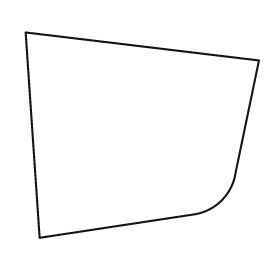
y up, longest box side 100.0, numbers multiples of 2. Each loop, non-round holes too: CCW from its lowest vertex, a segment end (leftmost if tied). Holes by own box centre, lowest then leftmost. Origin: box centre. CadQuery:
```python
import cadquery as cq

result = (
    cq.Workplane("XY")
    .moveTo(-44.0, -44.0)
    .lineTo(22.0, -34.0)
    .threePointArc((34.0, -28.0), (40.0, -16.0))
    .lineTo(50.0, 32.0)
    .lineTo(-50.0, 44.0)
    .close()
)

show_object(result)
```